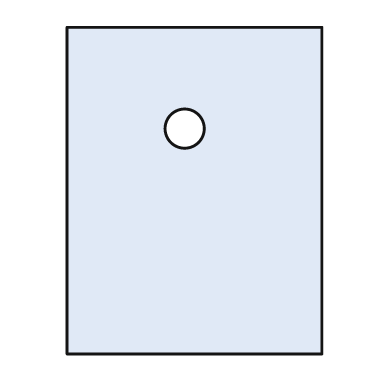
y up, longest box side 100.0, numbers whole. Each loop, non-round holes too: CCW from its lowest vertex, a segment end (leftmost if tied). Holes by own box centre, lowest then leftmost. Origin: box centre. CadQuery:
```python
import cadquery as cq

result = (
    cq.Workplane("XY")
    .moveTo(-39.0, -50.0)
    .lineTo(39.0, -50.0)
    .lineTo(39.0, 50.0)
    .lineTo(-39.0, 50.0)
    .close()
    .moveTo(-3.0, 19.0)
    .circle(6.0)
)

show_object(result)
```